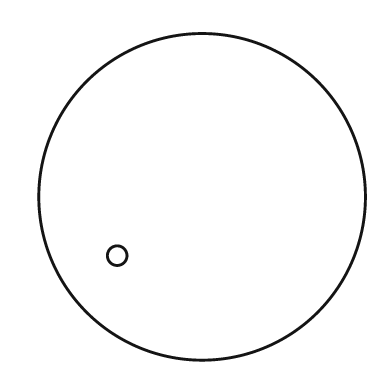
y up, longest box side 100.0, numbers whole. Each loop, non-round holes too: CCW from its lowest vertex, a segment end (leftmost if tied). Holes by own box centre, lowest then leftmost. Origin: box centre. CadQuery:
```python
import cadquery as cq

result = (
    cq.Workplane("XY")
    .moveTo(0.0, 0.0)
    .circle(50.0)
    .moveTo(-26.0, -18.0)
    .circle(3.0)
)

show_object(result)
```